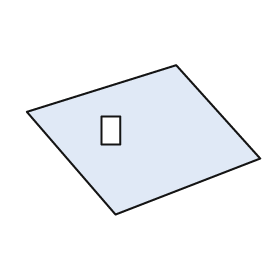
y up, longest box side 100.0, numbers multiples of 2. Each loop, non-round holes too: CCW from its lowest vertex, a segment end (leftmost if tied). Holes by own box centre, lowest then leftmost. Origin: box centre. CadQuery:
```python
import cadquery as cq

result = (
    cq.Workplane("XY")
    .moveTo(-12.0, -32.0)
    .lineTo(50.0, -8.0)
    .lineTo(14.0, 32.0)
    .lineTo(-50.0, 12.0)
    .close()
    .moveTo(-18.0, -2.0)
    .lineTo(-10.0, -2.0)
    .lineTo(-10.0, 10.0)
    .lineTo(-18.0, 10.0)
    .close()
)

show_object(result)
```